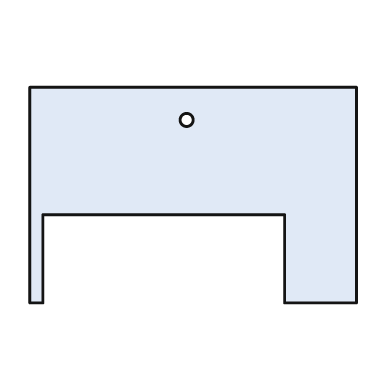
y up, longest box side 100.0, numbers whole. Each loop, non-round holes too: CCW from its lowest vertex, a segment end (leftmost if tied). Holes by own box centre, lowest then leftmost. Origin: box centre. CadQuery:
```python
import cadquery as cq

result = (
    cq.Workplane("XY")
    .moveTo(-50.0, -33.0)
    .lineTo(-46.0, -33.0)
    .lineTo(-46.0, -6.0)
    .lineTo(28.0, -6.0)
    .lineTo(28.0, -33.0)
    .lineTo(50.0, -33.0)
    .lineTo(50.0, 33.0)
    .lineTo(-50.0, 33.0)
    .close()
    .moveTo(-2.0, 23.0)
    .circle(2.0)
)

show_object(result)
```